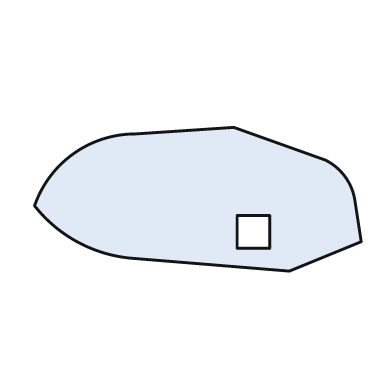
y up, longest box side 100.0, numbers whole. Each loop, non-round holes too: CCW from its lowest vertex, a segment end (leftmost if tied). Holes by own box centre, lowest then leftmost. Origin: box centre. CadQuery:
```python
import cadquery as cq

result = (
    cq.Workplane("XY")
    .moveTo(28.0, -22.0)
    .lineTo(50.0, -13.0)
    .lineTo(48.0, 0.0)
    .threePointArc((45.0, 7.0), (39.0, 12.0))
    .lineTo(11.0, 22.0)
    .lineTo(-19.0, 20.0)
    .threePointArc((-38.0, 14.0), (-50.0, -2.0))
    .threePointArc((-37.0, -13.0), (-21.0, -18.0))
    .close()
    .moveTo(12.0, -15.0)
    .lineTo(22.0, -15.0)
    .lineTo(22.0, -5.0)
    .lineTo(12.0, -5.0)
    .close()
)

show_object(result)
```